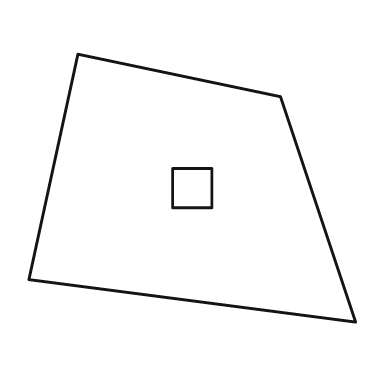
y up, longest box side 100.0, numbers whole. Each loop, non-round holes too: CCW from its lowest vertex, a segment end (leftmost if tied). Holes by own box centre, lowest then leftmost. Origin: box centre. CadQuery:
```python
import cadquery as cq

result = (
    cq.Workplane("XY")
    .moveTo(50.0, -41.0)
    .lineTo(27.0, 28.0)
    .lineTo(-35.0, 41.0)
    .lineTo(-50.0, -28.0)
    .close()
    .moveTo(-6.0, -6.0)
    .lineTo(6.0, -6.0)
    .lineTo(6.0, 6.0)
    .lineTo(-6.0, 6.0)
    .close()
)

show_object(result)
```